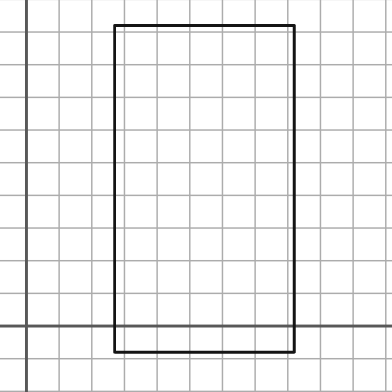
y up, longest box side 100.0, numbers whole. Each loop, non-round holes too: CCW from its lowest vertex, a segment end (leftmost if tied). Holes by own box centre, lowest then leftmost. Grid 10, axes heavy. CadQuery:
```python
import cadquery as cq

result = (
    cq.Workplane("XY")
    .moveTo(27.0, -8.0)
    .lineTo(82.0, -8.0)
    .lineTo(82.0, 92.0)
    .lineTo(27.0, 92.0)
    .close()
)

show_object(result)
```